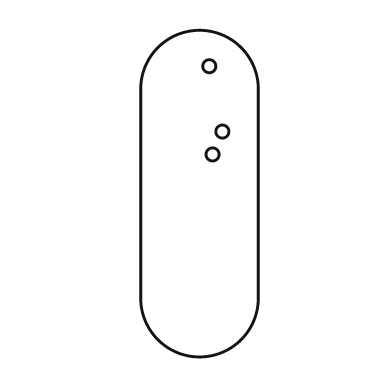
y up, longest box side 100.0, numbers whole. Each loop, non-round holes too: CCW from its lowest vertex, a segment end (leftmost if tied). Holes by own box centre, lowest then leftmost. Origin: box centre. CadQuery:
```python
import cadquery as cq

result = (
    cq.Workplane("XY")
    .moveTo(-18.0, -32.0)
    .threePointArc((0.0, -50.0), (18.0, -32.0))
    .lineTo(18.0, 32.0)
    .threePointArc((0.0, 50.0), (-18.0, 32.0))
    .close()
    .moveTo(4.0, 12.0)
    .circle(2.0)
    .moveTo(7.0, 19.0)
    .circle(2.0)
    .moveTo(3.0, 39.0)
    .circle(2.0)
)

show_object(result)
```